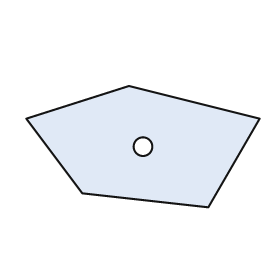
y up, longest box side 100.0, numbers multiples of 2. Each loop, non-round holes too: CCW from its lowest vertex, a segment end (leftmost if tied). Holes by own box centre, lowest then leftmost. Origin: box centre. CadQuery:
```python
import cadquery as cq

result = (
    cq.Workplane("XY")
    .moveTo(28.0, -26.0)
    .lineTo(50.0, 12.0)
    .lineTo(-6.0, 26.0)
    .lineTo(-50.0, 12.0)
    .lineTo(-26.0, -20.0)
    .close()
    .moveTo(0.0, 0.0)
    .circle(4.0)
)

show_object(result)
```